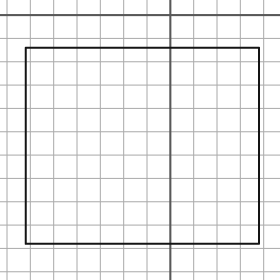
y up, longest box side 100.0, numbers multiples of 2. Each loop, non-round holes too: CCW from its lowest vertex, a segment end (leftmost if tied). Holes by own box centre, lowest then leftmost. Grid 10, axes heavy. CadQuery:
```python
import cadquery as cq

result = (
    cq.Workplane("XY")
    .moveTo(-62.0, -98.0)
    .lineTo(38.0, -98.0)
    .lineTo(38.0, -14.0)
    .lineTo(-62.0, -14.0)
    .close()
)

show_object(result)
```